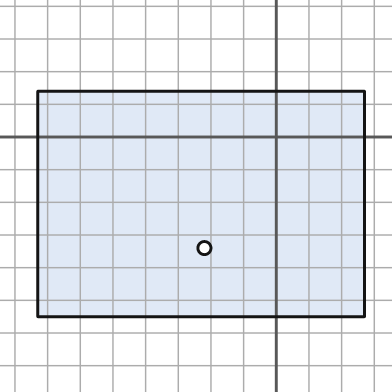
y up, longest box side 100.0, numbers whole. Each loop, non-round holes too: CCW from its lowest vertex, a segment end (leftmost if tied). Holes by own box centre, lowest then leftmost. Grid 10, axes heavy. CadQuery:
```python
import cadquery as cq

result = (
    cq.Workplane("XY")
    .moveTo(-73.0, -55.0)
    .lineTo(27.0, -55.0)
    .lineTo(27.0, 14.0)
    .lineTo(-73.0, 14.0)
    .close()
    .moveTo(-22.0, -34.0)
    .circle(2.0)
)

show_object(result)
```